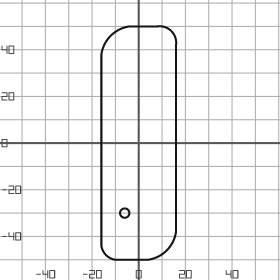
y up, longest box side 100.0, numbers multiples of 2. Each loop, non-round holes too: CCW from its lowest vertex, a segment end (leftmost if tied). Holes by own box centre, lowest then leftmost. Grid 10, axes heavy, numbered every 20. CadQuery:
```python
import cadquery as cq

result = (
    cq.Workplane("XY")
    .moveTo(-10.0, -50.0)
    .lineTo(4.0, -50.0)
    .threePointArc((12.0, -46.0), (16.0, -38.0))
    .lineTo(16.0, 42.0)
    .threePointArc((14.0, 48.0), (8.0, 50.0))
    .lineTo(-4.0, 50.0)
    .threePointArc((-12.0, 46.0), (-16.0, 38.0))
    .lineTo(-16.0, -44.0)
    .threePointArc((-14.0, -48.0), (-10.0, -50.0))
    .close()
    .moveTo(-6.0, -30.0)
    .circle(2.0)
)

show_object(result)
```